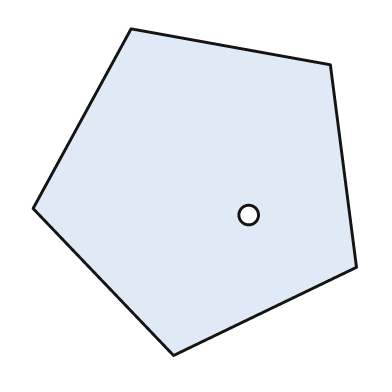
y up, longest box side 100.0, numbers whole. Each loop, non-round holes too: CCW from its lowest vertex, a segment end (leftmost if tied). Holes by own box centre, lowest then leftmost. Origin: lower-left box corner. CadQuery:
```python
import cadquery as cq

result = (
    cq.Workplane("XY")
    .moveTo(43.0, 0.0)
    .lineTo(99.0, 27.0)
    .lineTo(91.0, 89.0)
    .lineTo(30.0, 100.0)
    .lineTo(0.0, 45.0)
    .close()
    .moveTo(66.0, 43.0)
    .circle(3.0)
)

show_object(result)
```